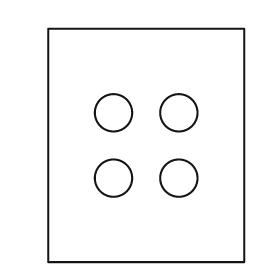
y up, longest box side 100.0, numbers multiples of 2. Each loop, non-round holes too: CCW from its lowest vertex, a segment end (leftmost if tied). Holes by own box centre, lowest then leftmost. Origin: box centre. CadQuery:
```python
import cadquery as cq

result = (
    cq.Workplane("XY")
    .moveTo(-42.0, -50.0)
    .lineTo(42.0, -50.0)
    .lineTo(42.0, 50.0)
    .lineTo(-42.0, 50.0)
    .close()
    .moveTo(-14.0, -14.0)
    .circle(8.0)
    .moveTo(14.0, -14.0)
    .circle(8.0)
    .moveTo(-14.0, 14.0)
    .circle(8.0)
    .moveTo(14.0, 14.0)
    .circle(8.0)
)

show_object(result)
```